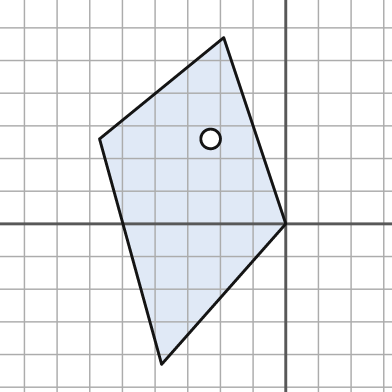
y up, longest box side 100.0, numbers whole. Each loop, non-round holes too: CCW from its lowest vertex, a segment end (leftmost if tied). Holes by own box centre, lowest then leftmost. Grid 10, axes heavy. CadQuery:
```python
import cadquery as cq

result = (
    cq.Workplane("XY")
    .moveTo(-38.0, -43.0)
    .lineTo(0.0, 0.0)
    .lineTo(-19.0, 57.0)
    .lineTo(-57.0, 26.0)
    .close()
    .moveTo(-23.0, 26.0)
    .circle(3.0)
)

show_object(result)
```